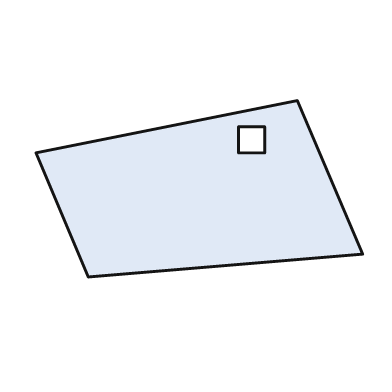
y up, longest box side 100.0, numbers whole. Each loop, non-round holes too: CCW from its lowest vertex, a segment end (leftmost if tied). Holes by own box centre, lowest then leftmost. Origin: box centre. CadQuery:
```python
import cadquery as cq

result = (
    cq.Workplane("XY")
    .moveTo(-34.0, -27.0)
    .lineTo(50.0, -20.0)
    .lineTo(30.0, 27.0)
    .lineTo(-50.0, 11.0)
    .close()
    .moveTo(12.0, 11.0)
    .lineTo(20.0, 11.0)
    .lineTo(20.0, 19.0)
    .lineTo(12.0, 19.0)
    .close()
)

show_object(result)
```